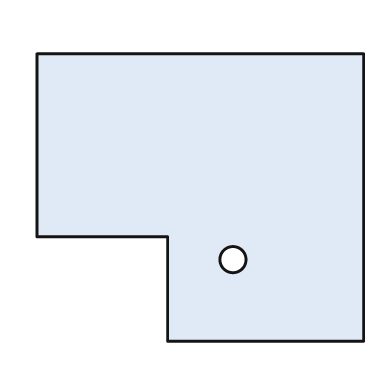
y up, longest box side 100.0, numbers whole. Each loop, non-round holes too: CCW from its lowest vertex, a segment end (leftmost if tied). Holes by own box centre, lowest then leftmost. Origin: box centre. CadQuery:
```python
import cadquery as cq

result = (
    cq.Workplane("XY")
    .moveTo(-10.0, -44.0)
    .lineTo(50.0, -44.0)
    .lineTo(50.0, 44.0)
    .lineTo(-50.0, 44.0)
    .lineTo(-50.0, -12.0)
    .lineTo(-10.0, -12.0)
    .close()
    .moveTo(10.0, -19.0)
    .circle(4.0)
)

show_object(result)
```